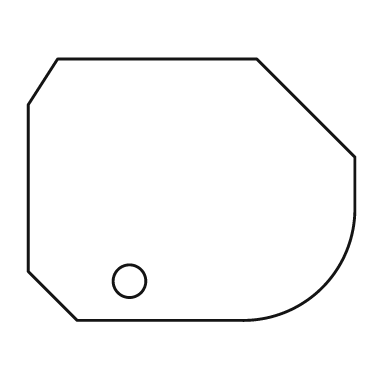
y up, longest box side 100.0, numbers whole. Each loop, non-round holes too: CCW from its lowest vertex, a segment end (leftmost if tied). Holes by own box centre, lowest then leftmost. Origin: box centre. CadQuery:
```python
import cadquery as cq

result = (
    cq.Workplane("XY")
    .moveTo(-35.0, -40.0)
    .lineTo(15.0, -40.0)
    .threePointArc((40.0, -30.0), (50.0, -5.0))
    .lineTo(50.0, 10.0)
    .lineTo(20.0, 40.0)
    .lineTo(-41.0, 40.0)
    .lineTo(-50.0, 26.0)
    .lineTo(-50.0, -25.0)
    .close()
    .moveTo(-19.0, -28.0)
    .circle(5.0)
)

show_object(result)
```